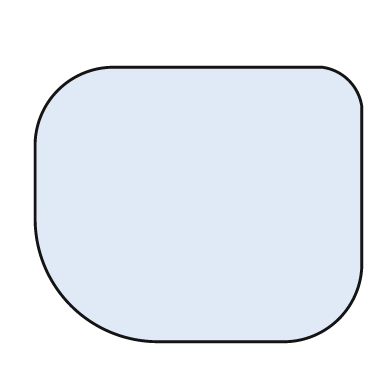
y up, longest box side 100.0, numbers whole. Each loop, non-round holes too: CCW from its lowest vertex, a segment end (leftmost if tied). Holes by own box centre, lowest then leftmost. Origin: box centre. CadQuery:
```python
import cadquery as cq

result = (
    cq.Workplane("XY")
    .moveTo(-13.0, -42.0)
    .lineTo(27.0, -42.0)
    .threePointArc((43.0, -35.0), (50.0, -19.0))
    .lineTo(50.0, 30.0)
    .threePointArc((46.0, 38.0), (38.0, 42.0))
    .lineTo(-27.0, 42.0)
    .threePointArc((-43.0, 35.0), (-50.0, 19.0))
    .lineTo(-50.0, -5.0)
    .threePointArc((-39.0, -31.0), (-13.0, -42.0))
    .close()
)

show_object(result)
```